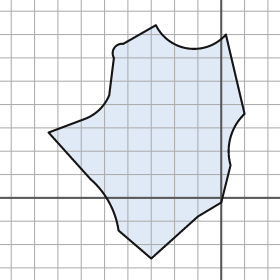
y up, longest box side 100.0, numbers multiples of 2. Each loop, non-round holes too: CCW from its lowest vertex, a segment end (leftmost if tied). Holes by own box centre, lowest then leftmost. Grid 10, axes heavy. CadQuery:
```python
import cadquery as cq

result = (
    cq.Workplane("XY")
    .moveTo(-30.0, -26.0)
    .lineTo(-10.0, -8.0)
    .lineTo(0.0, -2.0)
    .lineTo(4.0, 14.0)
    .threePointArc((4.0, 26.0), (10.0, 36.0))
    .lineTo(2.0, 70.0)
    .threePointArc((-14.0, 64.0), (-28.0, 74.0))
    .lineTo(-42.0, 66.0)
    .threePointArc((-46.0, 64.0), (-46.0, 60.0))
    .lineTo(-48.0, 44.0)
    .threePointArc((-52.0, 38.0), (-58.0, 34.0))
    .lineTo(-74.0, 28.0)
    .lineTo(-56.0, 8.0)
    .threePointArc((-48.0, -2.0), (-44.0, -14.0))
    .close()
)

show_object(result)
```